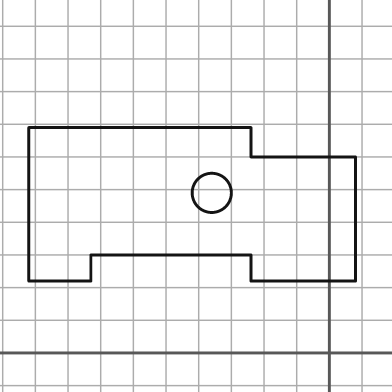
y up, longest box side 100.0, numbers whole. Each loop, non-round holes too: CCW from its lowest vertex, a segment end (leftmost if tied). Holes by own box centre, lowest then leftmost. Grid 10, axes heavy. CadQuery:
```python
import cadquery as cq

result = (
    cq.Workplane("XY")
    .moveTo(-92.0, 22.0)
    .lineTo(-73.0, 22.0)
    .lineTo(-73.0, 30.0)
    .lineTo(-24.0, 30.0)
    .lineTo(-24.0, 22.0)
    .lineTo(8.0, 22.0)
    .lineTo(8.0, 60.0)
    .lineTo(-24.0, 60.0)
    .lineTo(-24.0, 69.0)
    .lineTo(-92.0, 69.0)
    .close()
    .moveTo(-36.0, 49.0)
    .circle(6.0)
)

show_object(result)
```